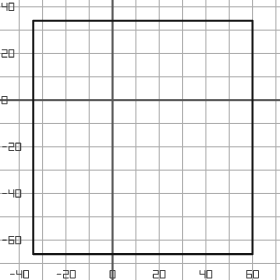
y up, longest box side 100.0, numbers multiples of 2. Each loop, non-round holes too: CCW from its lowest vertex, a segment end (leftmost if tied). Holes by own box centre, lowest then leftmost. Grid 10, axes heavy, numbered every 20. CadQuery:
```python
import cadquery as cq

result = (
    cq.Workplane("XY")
    .moveTo(-34.0, -66.0)
    .lineTo(60.0, -66.0)
    .lineTo(60.0, 34.0)
    .lineTo(-34.0, 34.0)
    .close()
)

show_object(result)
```